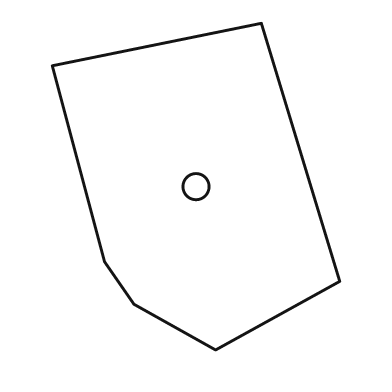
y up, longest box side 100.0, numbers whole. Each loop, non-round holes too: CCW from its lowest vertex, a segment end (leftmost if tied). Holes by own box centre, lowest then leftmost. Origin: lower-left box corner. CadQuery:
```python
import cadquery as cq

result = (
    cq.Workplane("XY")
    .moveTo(50.0, 0.0)
    .lineTo(88.0, 21.0)
    .lineTo(64.0, 100.0)
    .lineTo(0.0, 87.0)
    .lineTo(16.0, 27.0)
    .lineTo(25.0, 14.0)
    .close()
    .moveTo(44.0, 50.0)
    .circle(4.0)
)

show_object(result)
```